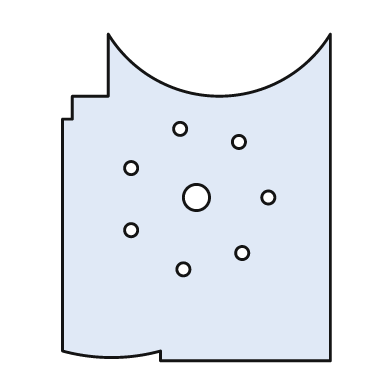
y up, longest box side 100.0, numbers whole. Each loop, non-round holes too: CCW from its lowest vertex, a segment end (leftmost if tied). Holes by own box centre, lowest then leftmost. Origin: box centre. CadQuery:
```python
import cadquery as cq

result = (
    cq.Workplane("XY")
    .moveTo(-11.0, -50.0)
    .lineTo(41.0, -50.0)
    .lineTo(41.0, 50.0)
    .threePointArc((7.0, 31.0), (-27.0, 50.0))
    .lineTo(-27.0, 31.0)
    .lineTo(-38.0, 31.0)
    .lineTo(-38.0, 24.0)
    .lineTo(-41.0, 24.0)
    .lineTo(-41.0, -47.0)
    .threePointArc((-26.0, -49.0), (-11.0, -47.0))
    .close()
    .moveTo(-4.0, -22.0)
    .circle(2.0)
    .moveTo(14.0, -17.0)
    .circle(2.0)
    .moveTo(-20.0, -10.0)
    .circle(2.0)
    .moveTo(0.0, 0.0)
    .circle(4.0)
    .moveTo(22.0, 0.0)
    .circle(2.0)
    .moveTo(-20.0, 9.0)
    .circle(2.0)
    .moveTo(13.0, 17.0)
    .circle(2.0)
    .moveTo(-5.0, 21.0)
    .circle(2.0)
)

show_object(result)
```